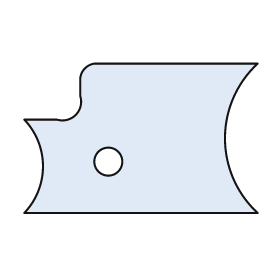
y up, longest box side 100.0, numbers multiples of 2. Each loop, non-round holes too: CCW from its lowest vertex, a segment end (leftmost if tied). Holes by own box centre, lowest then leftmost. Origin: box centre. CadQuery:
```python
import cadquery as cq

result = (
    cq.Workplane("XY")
    .moveTo(-50.0, -32.0)
    .lineTo(50.0, -32.0)
    .threePointArc((36.0, 0.0), (50.0, 32.0))
    .lineTo(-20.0, 32.0)
    .threePointArc((-24.0, 30.0), (-26.0, 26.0))
    .lineTo(-26.0, 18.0)
    .threePointArc((-28.0, 10.0), (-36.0, 8.0))
    .lineTo(-50.0, 8.0)
    .threePointArc((-42.0, -12.0), (-50.0, -32.0))
    .close()
    .moveTo(-14.0, -10.0)
    .circle(6.0)
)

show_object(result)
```